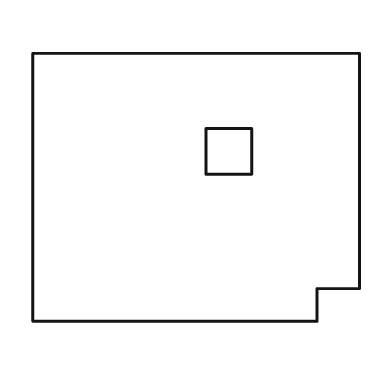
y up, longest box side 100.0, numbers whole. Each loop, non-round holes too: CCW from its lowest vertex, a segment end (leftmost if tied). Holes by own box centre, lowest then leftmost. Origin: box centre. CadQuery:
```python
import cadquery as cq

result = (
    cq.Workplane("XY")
    .moveTo(-50.0, -41.0)
    .lineTo(37.0, -41.0)
    .lineTo(37.0, -31.0)
    .lineTo(50.0, -31.0)
    .lineTo(50.0, 41.0)
    .lineTo(-50.0, 41.0)
    .close()
    .moveTo(3.0, 4.0)
    .lineTo(17.0, 4.0)
    .lineTo(17.0, 18.0)
    .lineTo(3.0, 18.0)
    .close()
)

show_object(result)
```